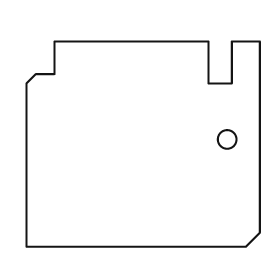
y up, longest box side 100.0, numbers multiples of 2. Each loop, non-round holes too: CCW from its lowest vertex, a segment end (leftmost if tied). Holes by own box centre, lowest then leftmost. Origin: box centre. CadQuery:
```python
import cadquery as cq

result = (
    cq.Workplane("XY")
    .moveTo(-50.0, -44.0)
    .lineTo(44.0, -44.0)
    .lineTo(50.0, -38.0)
    .lineTo(50.0, 44.0)
    .lineTo(38.0, 44.0)
    .lineTo(38.0, 26.0)
    .lineTo(28.0, 26.0)
    .lineTo(28.0, 44.0)
    .lineTo(-38.0, 44.0)
    .lineTo(-38.0, 30.0)
    .lineTo(-46.0, 30.0)
    .lineTo(-50.0, 26.0)
    .close()
    .moveTo(36.0, 2.0)
    .circle(4.0)
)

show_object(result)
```